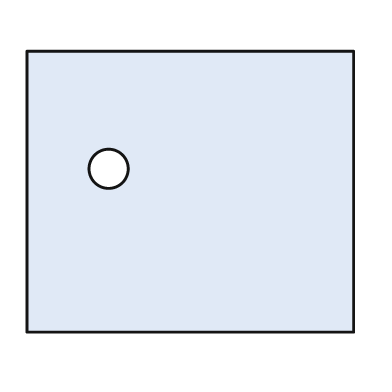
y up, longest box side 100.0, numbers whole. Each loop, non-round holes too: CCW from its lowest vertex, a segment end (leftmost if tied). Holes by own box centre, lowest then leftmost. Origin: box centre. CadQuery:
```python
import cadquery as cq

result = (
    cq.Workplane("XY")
    .moveTo(-50.0, -43.0)
    .lineTo(50.0, -43.0)
    .lineTo(50.0, 43.0)
    .lineTo(-50.0, 43.0)
    .close()
    .moveTo(-25.0, 7.0)
    .circle(6.0)
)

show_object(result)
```